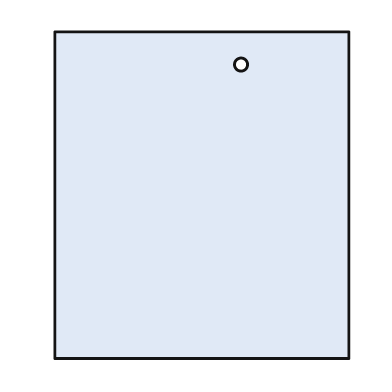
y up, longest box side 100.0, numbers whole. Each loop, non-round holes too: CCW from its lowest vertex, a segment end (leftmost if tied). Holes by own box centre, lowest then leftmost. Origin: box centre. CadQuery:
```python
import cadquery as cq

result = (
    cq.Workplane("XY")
    .moveTo(-45.0, -50.0)
    .lineTo(45.0, -50.0)
    .lineTo(45.0, 50.0)
    .lineTo(-45.0, 50.0)
    .close()
    .moveTo(12.0, 40.0)
    .circle(2.0)
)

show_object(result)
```